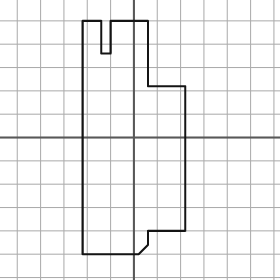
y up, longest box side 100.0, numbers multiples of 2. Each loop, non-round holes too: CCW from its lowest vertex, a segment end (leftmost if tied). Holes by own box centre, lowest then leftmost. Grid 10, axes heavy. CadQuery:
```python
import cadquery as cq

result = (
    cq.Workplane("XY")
    .moveTo(-22.0, -50.0)
    .lineTo(2.0, -50.0)
    .lineTo(6.0, -46.0)
    .lineTo(6.0, -40.0)
    .lineTo(22.0, -40.0)
    .lineTo(22.0, 22.0)
    .lineTo(6.0, 22.0)
    .lineTo(6.0, 50.0)
    .lineTo(-10.0, 50.0)
    .lineTo(-10.0, 36.0)
    .lineTo(-14.0, 36.0)
    .lineTo(-14.0, 50.0)
    .lineTo(-22.0, 50.0)
    .close()
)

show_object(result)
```